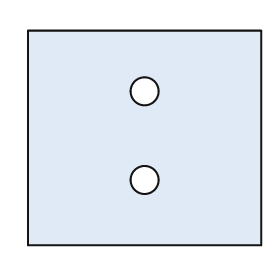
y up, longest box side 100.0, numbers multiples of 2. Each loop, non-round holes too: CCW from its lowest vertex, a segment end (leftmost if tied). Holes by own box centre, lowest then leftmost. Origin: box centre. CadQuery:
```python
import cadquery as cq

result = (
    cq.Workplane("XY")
    .moveTo(-50.0, -46.0)
    .lineTo(50.0, -46.0)
    .lineTo(50.0, 46.0)
    .lineTo(-50.0, 46.0)
    .close()
    .moveTo(0.0, -18.0)
    .circle(6.0)
    .moveTo(0.0, 20.0)
    .circle(6.0)
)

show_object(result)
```